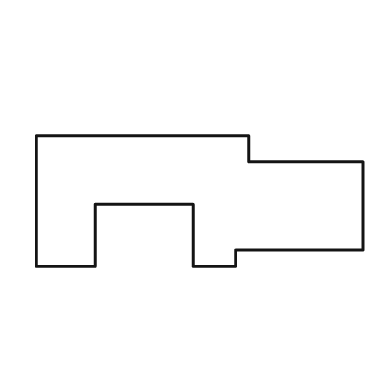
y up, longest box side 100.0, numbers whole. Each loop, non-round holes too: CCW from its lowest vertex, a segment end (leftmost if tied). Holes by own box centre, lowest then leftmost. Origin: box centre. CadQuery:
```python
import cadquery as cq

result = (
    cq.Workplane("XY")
    .moveTo(-50.0, -20.0)
    .lineTo(-32.0, -20.0)
    .lineTo(-32.0, -1.0)
    .lineTo(-2.0, -1.0)
    .lineTo(-2.0, -20.0)
    .lineTo(11.0, -20.0)
    .lineTo(11.0, -15.0)
    .lineTo(50.0, -15.0)
    .lineTo(50.0, 12.0)
    .lineTo(15.0, 12.0)
    .lineTo(15.0, 20.0)
    .lineTo(-50.0, 20.0)
    .close()
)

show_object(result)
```